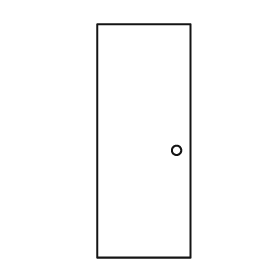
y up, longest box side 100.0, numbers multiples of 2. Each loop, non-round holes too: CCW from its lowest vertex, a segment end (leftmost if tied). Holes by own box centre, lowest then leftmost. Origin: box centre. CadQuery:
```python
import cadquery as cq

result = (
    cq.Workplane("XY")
    .moveTo(-20.0, -50.0)
    .lineTo(20.0, -50.0)
    .lineTo(20.0, 50.0)
    .lineTo(-20.0, 50.0)
    .close()
    .moveTo(14.0, -4.0)
    .circle(2.0)
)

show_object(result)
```